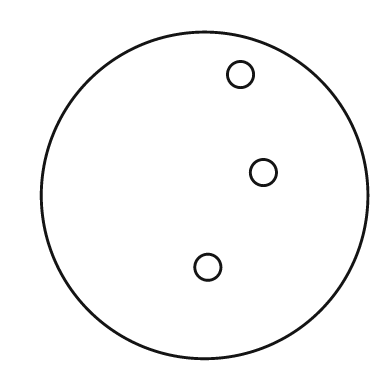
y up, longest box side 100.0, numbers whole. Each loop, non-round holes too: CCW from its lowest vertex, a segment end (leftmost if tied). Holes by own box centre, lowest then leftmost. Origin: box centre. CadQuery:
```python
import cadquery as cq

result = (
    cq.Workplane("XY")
    .moveTo(0.0, 0.0)
    .circle(50.0)
    .moveTo(1.0, -22.0)
    .circle(4.0)
    .moveTo(18.0, 7.0)
    .circle(4.0)
    .moveTo(11.0, 37.0)
    .circle(4.0)
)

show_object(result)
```